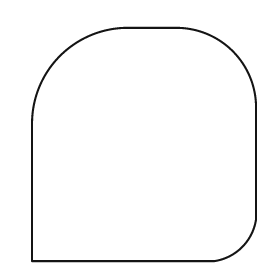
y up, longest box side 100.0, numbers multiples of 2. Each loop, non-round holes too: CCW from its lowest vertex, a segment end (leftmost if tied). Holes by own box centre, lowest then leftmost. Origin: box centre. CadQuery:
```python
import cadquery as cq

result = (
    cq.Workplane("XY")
    .moveTo(-48.0, -50.0)
    .lineTo(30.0, -50.0)
    .threePointArc((42.0, -44.0), (48.0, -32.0))
    .lineTo(48.0, 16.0)
    .threePointArc((38.0, 40.0), (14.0, 50.0))
    .lineTo(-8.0, 50.0)
    .threePointArc((-36.0, 38.0), (-48.0, 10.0))
    .close()
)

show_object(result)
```